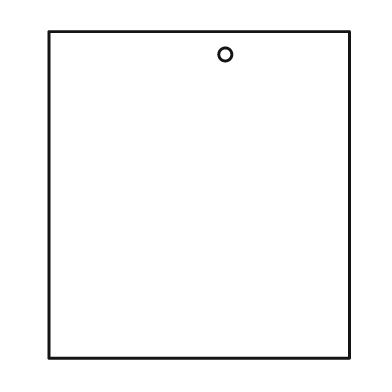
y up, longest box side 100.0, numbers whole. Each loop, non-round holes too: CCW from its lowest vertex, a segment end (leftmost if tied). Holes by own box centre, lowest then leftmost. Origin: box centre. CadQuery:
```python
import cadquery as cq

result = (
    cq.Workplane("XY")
    .moveTo(-46.0, -50.0)
    .lineTo(46.0, -50.0)
    .lineTo(46.0, 50.0)
    .lineTo(-46.0, 50.0)
    .close()
    .moveTo(8.0, 43.0)
    .circle(2.0)
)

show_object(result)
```